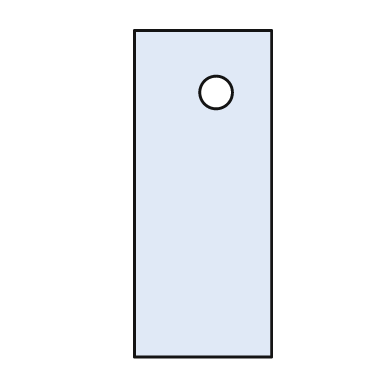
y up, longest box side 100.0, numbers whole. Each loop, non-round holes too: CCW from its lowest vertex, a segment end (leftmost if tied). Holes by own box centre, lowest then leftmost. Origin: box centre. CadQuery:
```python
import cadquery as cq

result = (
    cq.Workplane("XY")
    .moveTo(-21.0, -50.0)
    .lineTo(21.0, -50.0)
    .lineTo(21.0, 50.0)
    .lineTo(-21.0, 50.0)
    .close()
    .moveTo(4.0, 31.0)
    .circle(5.0)
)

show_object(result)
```